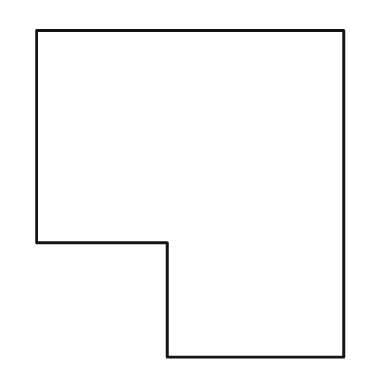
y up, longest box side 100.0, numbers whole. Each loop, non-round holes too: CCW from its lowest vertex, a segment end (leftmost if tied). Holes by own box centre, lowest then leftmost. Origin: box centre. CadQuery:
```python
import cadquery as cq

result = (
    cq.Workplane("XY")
    .moveTo(-7.0, -50.0)
    .lineTo(47.0, -50.0)
    .lineTo(47.0, 50.0)
    .lineTo(-47.0, 50.0)
    .lineTo(-47.0, -15.0)
    .lineTo(-7.0, -15.0)
    .close()
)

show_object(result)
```